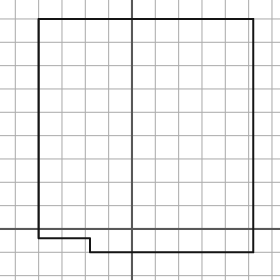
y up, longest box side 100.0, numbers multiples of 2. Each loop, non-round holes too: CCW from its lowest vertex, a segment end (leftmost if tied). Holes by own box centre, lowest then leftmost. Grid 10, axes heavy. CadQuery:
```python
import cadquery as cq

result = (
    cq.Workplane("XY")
    .moveTo(-18.0, -10.0)
    .lineTo(52.0, -10.0)
    .lineTo(52.0, 90.0)
    .lineTo(-40.0, 90.0)
    .lineTo(-40.0, -4.0)
    .lineTo(-18.0, -4.0)
    .close()
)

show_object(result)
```